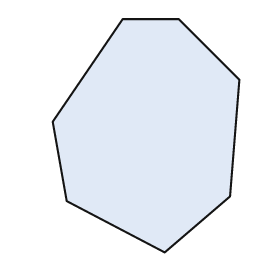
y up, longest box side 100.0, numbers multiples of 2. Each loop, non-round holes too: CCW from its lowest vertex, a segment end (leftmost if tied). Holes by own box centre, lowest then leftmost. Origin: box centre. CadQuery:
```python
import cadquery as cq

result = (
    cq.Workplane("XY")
    .moveTo(8.0, -50.0)
    .lineTo(36.0, -26.0)
    .lineTo(40.0, 24.0)
    .lineTo(14.0, 50.0)
    .lineTo(-10.0, 50.0)
    .lineTo(-40.0, 6.0)
    .lineTo(-34.0, -28.0)
    .close()
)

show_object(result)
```